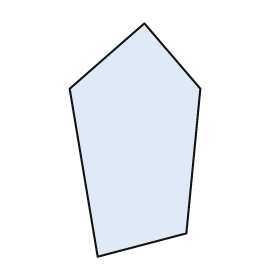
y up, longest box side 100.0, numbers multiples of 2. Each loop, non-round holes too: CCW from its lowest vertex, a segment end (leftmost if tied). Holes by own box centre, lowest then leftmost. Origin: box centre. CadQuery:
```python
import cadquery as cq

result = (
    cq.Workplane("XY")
    .moveTo(-16.0, -50.0)
    .lineTo(22.0, -40.0)
    .lineTo(28.0, 22.0)
    .lineTo(4.0, 50.0)
    .lineTo(-28.0, 22.0)
    .close()
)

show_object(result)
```